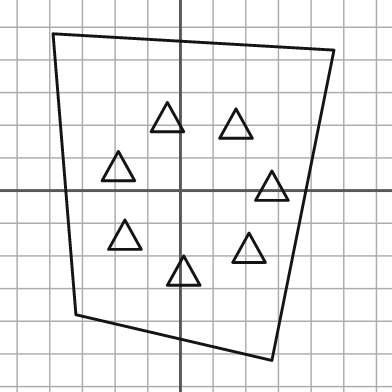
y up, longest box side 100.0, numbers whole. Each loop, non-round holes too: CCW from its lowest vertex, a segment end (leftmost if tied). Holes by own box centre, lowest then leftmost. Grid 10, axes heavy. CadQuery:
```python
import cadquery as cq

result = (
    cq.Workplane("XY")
    .moveTo(28.0, -52.0)
    .lineTo(47.0, 43.0)
    .lineTo(-39.0, 48.0)
    .lineTo(-32.0, -38.0)
    .close()
    .moveTo(-4.0, -29.0)
    .lineTo(6.0, -29.0)
    .lineTo(1.0, -20.0)
    .close()
    .moveTo(16.0, -22.0)
    .lineTo(26.0, -22.0)
    .lineTo(21.0, -13.0)
    .close()
    .moveTo(-22.0, -18.0)
    .lineTo(-12.0, -18.0)
    .lineTo(-17.0, -9.0)
    .close()
    .moveTo(23.0, -3.0)
    .lineTo(33.0, -3.0)
    .lineTo(28.0, 6.0)
    .close()
    .moveTo(-24.0, 3.0)
    .lineTo(-14.0, 3.0)
    .lineTo(-19.0, 12.0)
    .close()
    .moveTo(12.0, 16.0)
    .lineTo(22.0, 16.0)
    .lineTo(17.0, 25.0)
    .close()
    .moveTo(-9.0, 18.0)
    .lineTo(1.0, 18.0)
    .lineTo(-4.0, 27.0)
    .close()
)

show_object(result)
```